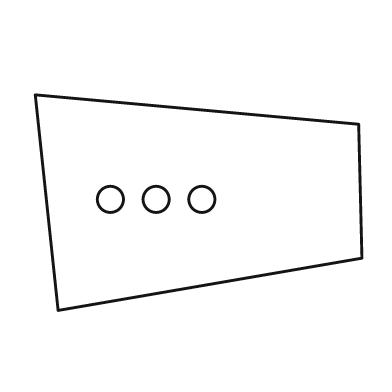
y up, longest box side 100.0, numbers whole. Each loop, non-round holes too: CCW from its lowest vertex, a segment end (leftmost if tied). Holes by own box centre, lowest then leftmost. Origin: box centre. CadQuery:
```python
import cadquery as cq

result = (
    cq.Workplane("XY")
    .moveTo(-43.0, -33.0)
    .lineTo(50.0, -17.0)
    .lineTo(49.0, 24.0)
    .lineTo(-50.0, 33.0)
    .close()
    .moveTo(-27.0, 1.0)
    .circle(4.0)
    .moveTo(-13.0, 1.0)
    .circle(4.0)
    .moveTo(1.0, 1.0)
    .circle(4.0)
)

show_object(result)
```